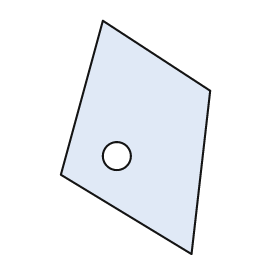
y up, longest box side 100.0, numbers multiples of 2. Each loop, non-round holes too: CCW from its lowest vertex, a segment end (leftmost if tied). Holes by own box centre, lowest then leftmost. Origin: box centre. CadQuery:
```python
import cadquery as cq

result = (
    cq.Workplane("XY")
    .moveTo(24.0, -50.0)
    .lineTo(32.0, 20.0)
    .lineTo(-14.0, 50.0)
    .lineTo(-32.0, -16.0)
    .close()
    .moveTo(-8.0, -8.0)
    .circle(6.0)
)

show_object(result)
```